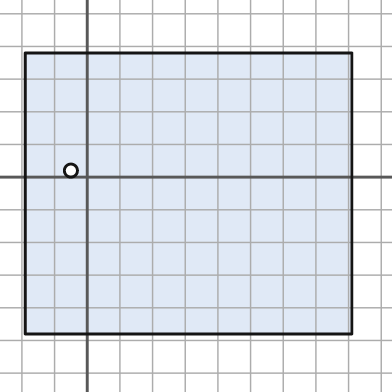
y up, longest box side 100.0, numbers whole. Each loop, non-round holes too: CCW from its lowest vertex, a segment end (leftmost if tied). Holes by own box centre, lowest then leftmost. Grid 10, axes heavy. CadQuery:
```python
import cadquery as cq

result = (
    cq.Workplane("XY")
    .moveTo(-19.0, -48.0)
    .lineTo(81.0, -48.0)
    .lineTo(81.0, 38.0)
    .lineTo(-19.0, 38.0)
    .close()
    .moveTo(-5.0, 2.0)
    .circle(2.0)
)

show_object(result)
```